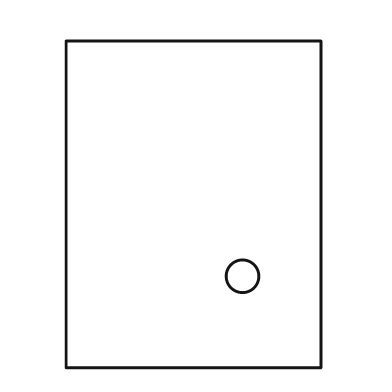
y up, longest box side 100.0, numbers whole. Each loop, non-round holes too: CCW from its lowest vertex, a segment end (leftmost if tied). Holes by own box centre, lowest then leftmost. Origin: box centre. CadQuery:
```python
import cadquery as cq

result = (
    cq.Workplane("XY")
    .moveTo(-39.0, -50.0)
    .lineTo(39.0, -50.0)
    .lineTo(39.0, 50.0)
    .lineTo(-39.0, 50.0)
    .close()
    .moveTo(15.0, -22.0)
    .circle(5.0)
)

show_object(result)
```